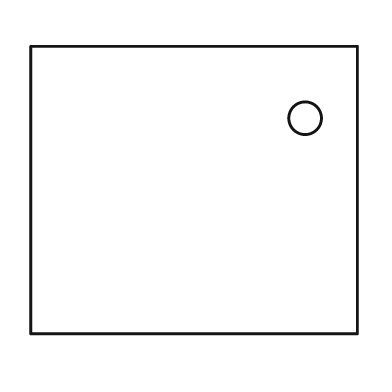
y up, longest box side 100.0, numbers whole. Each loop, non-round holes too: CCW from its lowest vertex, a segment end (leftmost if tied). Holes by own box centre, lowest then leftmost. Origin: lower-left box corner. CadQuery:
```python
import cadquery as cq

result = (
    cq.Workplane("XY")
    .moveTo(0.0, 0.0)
    .lineTo(100.0, 0.0)
    .lineTo(100.0, 88.0)
    .lineTo(0.0, 88.0)
    .close()
    .moveTo(84.0, 66.0)
    .circle(5.0)
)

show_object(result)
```